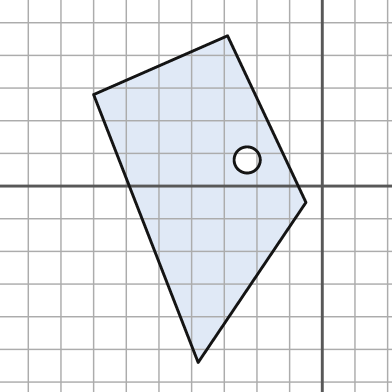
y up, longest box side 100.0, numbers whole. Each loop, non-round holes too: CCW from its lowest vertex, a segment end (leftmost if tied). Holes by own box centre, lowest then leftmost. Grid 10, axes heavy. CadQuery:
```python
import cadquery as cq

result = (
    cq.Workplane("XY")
    .moveTo(-38.0, -54.0)
    .lineTo(-5.0, -5.0)
    .lineTo(-29.0, 46.0)
    .lineTo(-70.0, 28.0)
    .close()
    .moveTo(-23.0, 8.0)
    .circle(4.0)
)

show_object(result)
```